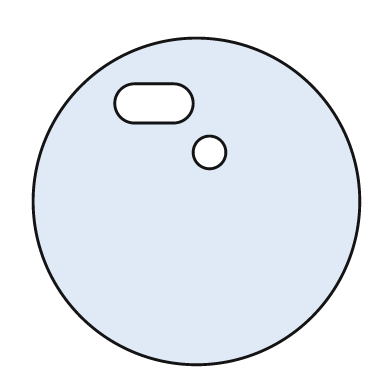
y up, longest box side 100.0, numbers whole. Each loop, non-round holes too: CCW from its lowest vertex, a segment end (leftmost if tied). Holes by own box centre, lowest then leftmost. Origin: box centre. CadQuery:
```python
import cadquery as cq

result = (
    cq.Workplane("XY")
    .moveTo(0.0, 0.0)
    .circle(50.0)
    .moveTo(4.0, 15.0)
    .circle(5.0)
    .moveTo(-19.0, 24.0)
    .lineTo(-7.0, 24.0)
    .threePointArc((-1.0, 30.0), (-7.0, 36.0))
    .lineTo(-19.0, 36.0)
    .threePointArc((-25.0, 30.0), (-19.0, 24.0))
    .close()
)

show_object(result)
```